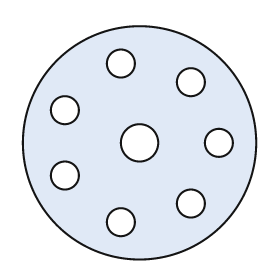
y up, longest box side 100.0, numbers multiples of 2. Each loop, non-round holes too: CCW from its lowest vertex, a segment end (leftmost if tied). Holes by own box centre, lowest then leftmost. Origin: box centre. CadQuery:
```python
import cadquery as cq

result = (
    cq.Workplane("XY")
    .moveTo(0.0, 0.0)
    .circle(50.0)
    .moveTo(-8.0, -34.0)
    .circle(6.0)
    .moveTo(22.0, -26.0)
    .circle(6.0)
    .moveTo(-32.0, -14.0)
    .circle(6.0)
    .moveTo(0.0, 0.0)
    .circle(8.0)
    .moveTo(34.0, 0.0)
    .circle(6.0)
    .moveTo(-32.0, 14.0)
    .circle(6.0)
    .moveTo(22.0, 26.0)
    .circle(6.0)
    .moveTo(-8.0, 34.0)
    .circle(6.0)
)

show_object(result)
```